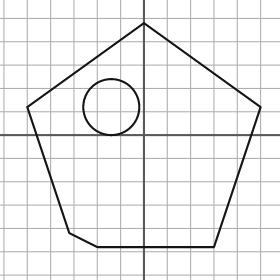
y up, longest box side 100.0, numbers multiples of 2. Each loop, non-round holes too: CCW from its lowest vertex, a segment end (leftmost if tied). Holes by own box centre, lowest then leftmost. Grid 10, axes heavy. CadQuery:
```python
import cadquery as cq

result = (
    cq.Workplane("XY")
    .moveTo(-20.0, -48.0)
    .lineTo(30.0, -48.0)
    .lineTo(50.0, 12.0)
    .lineTo(0.0, 48.0)
    .lineTo(-50.0, 12.0)
    .lineTo(-32.0, -42.0)
    .close()
    .moveTo(-14.0, 12.0)
    .circle(12.0)
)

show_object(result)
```